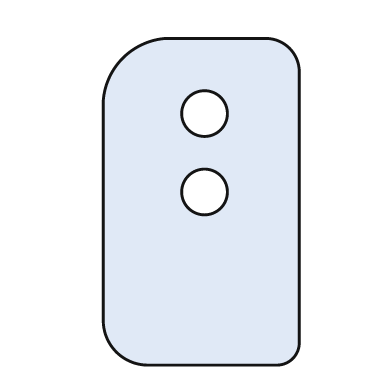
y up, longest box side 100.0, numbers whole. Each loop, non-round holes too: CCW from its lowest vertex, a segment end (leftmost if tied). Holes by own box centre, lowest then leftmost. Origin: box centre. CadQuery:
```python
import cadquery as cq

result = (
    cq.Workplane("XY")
    .moveTo(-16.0, -50.0)
    .lineTo(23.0, -50.0)
    .threePointArc((28.0, -48.0), (30.0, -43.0))
    .lineTo(30.0, 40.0)
    .threePointArc((27.0, 47.0), (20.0, 50.0))
    .lineTo(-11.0, 50.0)
    .threePointArc((-24.0, 44.0), (-30.0, 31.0))
    .lineTo(-30.0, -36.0)
    .threePointArc((-26.0, -46.0), (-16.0, -50.0))
    .close()
    .moveTo(1.0, 3.0)
    .circle(7.0)
    .moveTo(1.0, 27.0)
    .circle(7.0)
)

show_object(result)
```